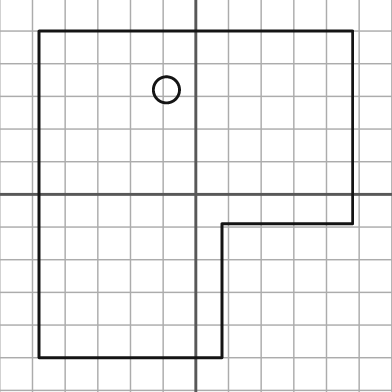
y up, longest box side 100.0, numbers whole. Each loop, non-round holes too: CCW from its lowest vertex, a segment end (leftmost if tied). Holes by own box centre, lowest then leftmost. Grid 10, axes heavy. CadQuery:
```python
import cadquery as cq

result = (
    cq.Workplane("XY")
    .moveTo(-48.0, -50.0)
    .lineTo(8.0, -50.0)
    .lineTo(8.0, -9.0)
    .lineTo(48.0, -9.0)
    .lineTo(48.0, 50.0)
    .lineTo(-48.0, 50.0)
    .close()
    .moveTo(-9.0, 32.0)
    .circle(4.0)
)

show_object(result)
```